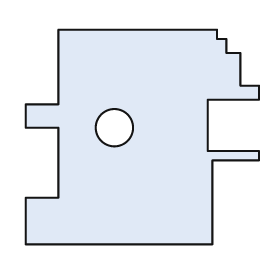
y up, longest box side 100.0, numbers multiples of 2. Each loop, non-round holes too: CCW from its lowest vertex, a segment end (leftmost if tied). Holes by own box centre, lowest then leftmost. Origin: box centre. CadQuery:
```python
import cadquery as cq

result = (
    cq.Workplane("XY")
    .moveTo(-50.0, -46.0)
    .lineTo(30.0, -46.0)
    .lineTo(30.0, -10.0)
    .lineTo(50.0, -10.0)
    .lineTo(50.0, -6.0)
    .lineTo(28.0, -6.0)
    .lineTo(28.0, 16.0)
    .lineTo(50.0, 16.0)
    .lineTo(50.0, 22.0)
    .lineTo(42.0, 22.0)
    .lineTo(42.0, 36.0)
    .lineTo(36.0, 36.0)
    .lineTo(36.0, 42.0)
    .lineTo(32.0, 42.0)
    .lineTo(32.0, 46.0)
    .lineTo(-36.0, 46.0)
    .lineTo(-36.0, 14.0)
    .lineTo(-50.0, 14.0)
    .lineTo(-50.0, 4.0)
    .lineTo(-36.0, 4.0)
    .lineTo(-36.0, -26.0)
    .lineTo(-50.0, -26.0)
    .close()
    .moveTo(-12.0, 4.0)
    .circle(8.0)
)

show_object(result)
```